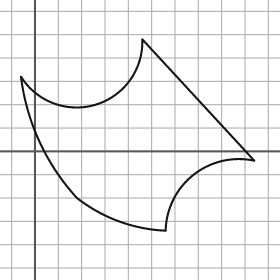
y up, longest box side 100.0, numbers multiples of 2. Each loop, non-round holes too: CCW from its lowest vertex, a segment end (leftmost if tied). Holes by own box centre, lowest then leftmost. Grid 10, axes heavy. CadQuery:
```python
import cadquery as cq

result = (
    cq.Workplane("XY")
    .moveTo(56.0, -34.0)
    .threePointArc((68.0, -10.0), (94.0, -4.0))
    .lineTo(46.0, 48.0)
    .threePointArc((26.0, 20.0), (-6.0, 32.0))
    .threePointArc((2.0, 4.0), (18.0, -20.0))
    .threePointArc((36.0, -30.0), (56.0, -34.0))
    .close()
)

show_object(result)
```